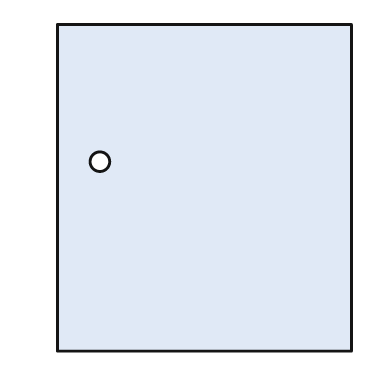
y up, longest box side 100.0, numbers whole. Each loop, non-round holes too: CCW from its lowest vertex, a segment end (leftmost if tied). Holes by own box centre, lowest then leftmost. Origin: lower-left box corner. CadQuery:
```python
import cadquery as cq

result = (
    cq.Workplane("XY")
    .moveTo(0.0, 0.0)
    .lineTo(90.0, 0.0)
    .lineTo(90.0, 100.0)
    .lineTo(0.0, 100.0)
    .close()
    .moveTo(13.0, 58.0)
    .circle(3.0)
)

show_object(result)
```